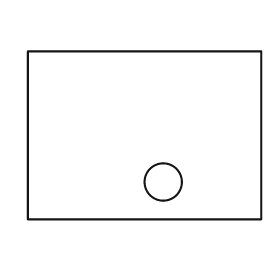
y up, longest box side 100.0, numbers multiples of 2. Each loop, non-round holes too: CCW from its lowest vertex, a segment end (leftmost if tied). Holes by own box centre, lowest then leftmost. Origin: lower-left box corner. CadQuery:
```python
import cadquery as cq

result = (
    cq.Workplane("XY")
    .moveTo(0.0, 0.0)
    .lineTo(100.0, 0.0)
    .lineTo(100.0, 72.0)
    .lineTo(0.0, 72.0)
    .close()
    .moveTo(58.0, 16.0)
    .circle(8.0)
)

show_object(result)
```